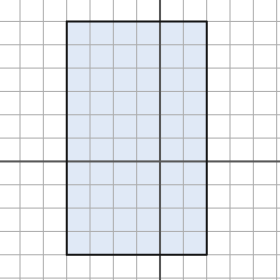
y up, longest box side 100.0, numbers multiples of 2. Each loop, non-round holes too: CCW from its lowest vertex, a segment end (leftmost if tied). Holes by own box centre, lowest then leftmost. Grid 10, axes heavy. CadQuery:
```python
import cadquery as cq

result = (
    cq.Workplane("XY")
    .moveTo(-40.0, -40.0)
    .lineTo(20.0, -40.0)
    .lineTo(20.0, 60.0)
    .lineTo(-40.0, 60.0)
    .close()
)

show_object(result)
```